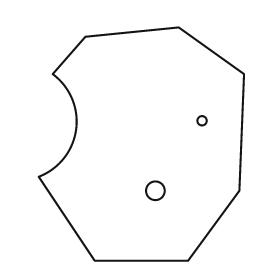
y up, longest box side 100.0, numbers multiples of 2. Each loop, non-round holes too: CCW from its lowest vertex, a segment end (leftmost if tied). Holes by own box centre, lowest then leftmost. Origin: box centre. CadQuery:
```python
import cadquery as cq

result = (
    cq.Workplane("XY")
    .moveTo(-20.0, -50.0)
    .lineTo(20.0, -50.0)
    .lineTo(42.0, -20.0)
    .lineTo(44.0, 30.0)
    .lineTo(16.0, 50.0)
    .lineTo(-24.0, 46.0)
    .lineTo(-38.0, 30.0)
    .threePointArc((-28.0, 6.0), (-44.0, -14.0))
    .close()
    .moveTo(6.0, -20.0)
    .circle(4.0)
    .moveTo(26.0, 10.0)
    .circle(2.0)
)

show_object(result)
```